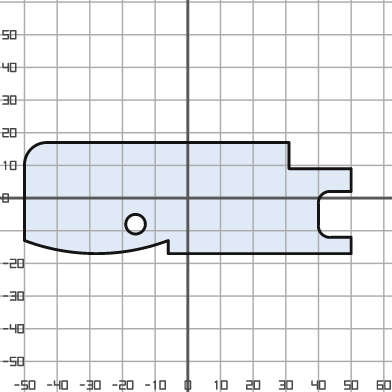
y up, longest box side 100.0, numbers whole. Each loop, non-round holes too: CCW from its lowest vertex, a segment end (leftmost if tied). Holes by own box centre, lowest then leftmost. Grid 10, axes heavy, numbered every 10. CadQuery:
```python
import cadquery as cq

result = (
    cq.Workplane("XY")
    .moveTo(-6.0, -17.0)
    .lineTo(50.0, -17.0)
    .lineTo(50.0, -12.0)
    .lineTo(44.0, -12.0)
    .threePointArc((41.0, -11.0), (40.0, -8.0))
    .lineTo(40.0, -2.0)
    .threePointArc((41.0, 1.0), (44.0, 2.0))
    .lineTo(50.0, 2.0)
    .lineTo(50.0, 9.0)
    .lineTo(31.0, 9.0)
    .lineTo(31.0, 17.0)
    .lineTo(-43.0, 17.0)
    .threePointArc((-48.0, 15.0), (-50.0, 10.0))
    .lineTo(-50.0, -13.0)
    .threePointArc((-28.0, -17.0), (-6.0, -13.0))
    .close()
    .moveTo(-16.0, -8.0)
    .circle(3.0)
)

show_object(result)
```